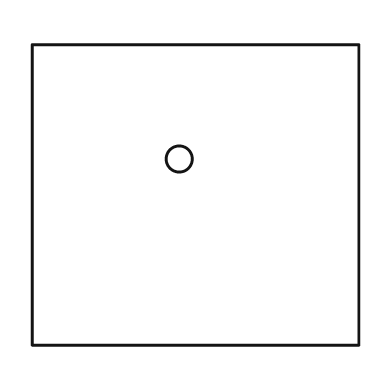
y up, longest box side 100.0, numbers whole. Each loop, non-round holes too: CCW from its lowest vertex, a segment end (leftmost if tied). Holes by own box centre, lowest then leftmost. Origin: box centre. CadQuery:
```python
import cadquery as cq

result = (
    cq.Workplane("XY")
    .moveTo(-50.0, -46.0)
    .lineTo(50.0, -46.0)
    .lineTo(50.0, 46.0)
    .lineTo(-50.0, 46.0)
    .close()
    .moveTo(-5.0, 11.0)
    .circle(4.0)
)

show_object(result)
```